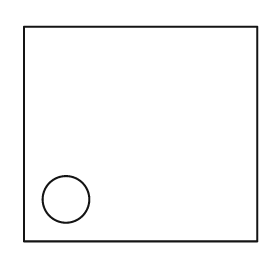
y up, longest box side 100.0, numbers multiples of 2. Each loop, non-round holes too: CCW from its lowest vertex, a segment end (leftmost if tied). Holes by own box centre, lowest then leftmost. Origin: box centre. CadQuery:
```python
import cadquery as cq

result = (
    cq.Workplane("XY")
    .moveTo(-50.0, -46.0)
    .lineTo(50.0, -46.0)
    .lineTo(50.0, 46.0)
    .lineTo(-50.0, 46.0)
    .close()
    .moveTo(-32.0, -28.0)
    .circle(10.0)
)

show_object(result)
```